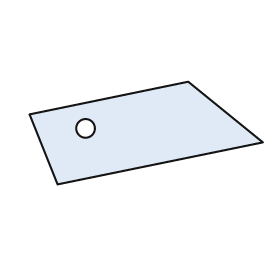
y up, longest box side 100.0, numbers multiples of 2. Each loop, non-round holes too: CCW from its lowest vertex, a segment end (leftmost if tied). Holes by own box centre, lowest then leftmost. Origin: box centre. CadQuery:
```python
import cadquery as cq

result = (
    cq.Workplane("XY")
    .moveTo(-38.0, -22.0)
    .lineTo(50.0, -4.0)
    .lineTo(18.0, 22.0)
    .lineTo(-50.0, 8.0)
    .close()
    .moveTo(-26.0, 2.0)
    .circle(4.0)
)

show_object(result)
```